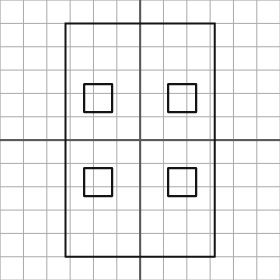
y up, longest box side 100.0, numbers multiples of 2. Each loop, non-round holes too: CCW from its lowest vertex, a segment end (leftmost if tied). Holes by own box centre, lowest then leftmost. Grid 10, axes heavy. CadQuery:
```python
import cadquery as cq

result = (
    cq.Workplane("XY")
    .moveTo(-32.0, -50.0)
    .lineTo(32.0, -50.0)
    .lineTo(32.0, 50.0)
    .lineTo(-32.0, 50.0)
    .close()
    .moveTo(-24.0, -24.0)
    .lineTo(-12.0, -24.0)
    .lineTo(-12.0, -12.0)
    .lineTo(-24.0, -12.0)
    .close()
    .moveTo(12.0, -24.0)
    .lineTo(24.0, -24.0)
    .lineTo(24.0, -12.0)
    .lineTo(12.0, -12.0)
    .close()
    .moveTo(-24.0, 12.0)
    .lineTo(-12.0, 12.0)
    .lineTo(-12.0, 24.0)
    .lineTo(-24.0, 24.0)
    .close()
    .moveTo(12.0, 12.0)
    .lineTo(24.0, 12.0)
    .lineTo(24.0, 24.0)
    .lineTo(12.0, 24.0)
    .close()
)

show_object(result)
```